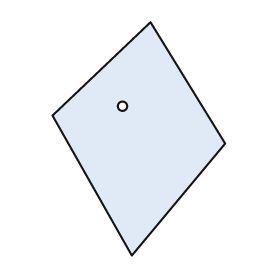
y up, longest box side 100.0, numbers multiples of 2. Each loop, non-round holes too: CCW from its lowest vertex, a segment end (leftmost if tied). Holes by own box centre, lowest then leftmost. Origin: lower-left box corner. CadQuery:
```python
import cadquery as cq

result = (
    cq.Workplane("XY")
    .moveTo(34.0, 0.0)
    .lineTo(74.0, 48.0)
    .lineTo(42.0, 100.0)
    .lineTo(0.0, 60.0)
    .close()
    .moveTo(30.0, 64.0)
    .circle(2.0)
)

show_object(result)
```